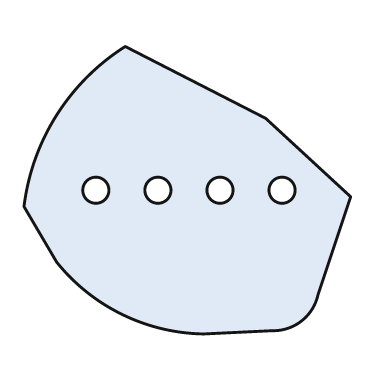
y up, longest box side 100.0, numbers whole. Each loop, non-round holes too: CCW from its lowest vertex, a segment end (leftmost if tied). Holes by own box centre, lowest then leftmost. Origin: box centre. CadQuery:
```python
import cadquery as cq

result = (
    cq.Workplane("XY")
    .moveTo(5.0, -44.0)
    .lineTo(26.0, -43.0)
    .threePointArc((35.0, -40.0), (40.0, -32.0))
    .lineTo(50.0, -2.0)
    .lineTo(24.0, 22.0)
    .lineTo(-19.0, 44.0)
    .threePointArc((-40.0, 23.0), (-50.0, -5.0))
    .lineTo(-40.0, -22.0)
    .threePointArc((-20.0, -38.0), (5.0, -44.0))
    .close()
    .moveTo(-28.0, 0.0)
    .circle(4.0)
    .moveTo(-9.0, 0.0)
    .circle(4.0)
    .moveTo(10.0, 0.0)
    .circle(4.0)
    .moveTo(29.0, 0.0)
    .circle(4.0)
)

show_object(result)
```